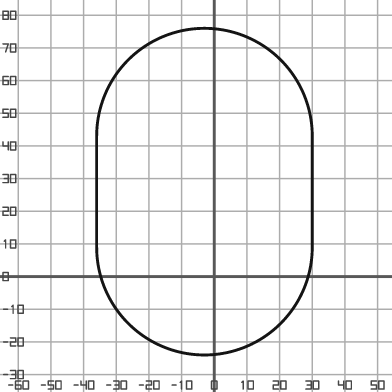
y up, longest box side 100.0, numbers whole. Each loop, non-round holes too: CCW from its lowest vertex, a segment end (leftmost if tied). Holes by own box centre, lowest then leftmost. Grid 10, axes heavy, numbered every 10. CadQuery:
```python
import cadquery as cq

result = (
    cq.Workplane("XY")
    .moveTo(-36.0, 9.0)
    .threePointArc((-3.0, -24.0), (30.0, 9.0))
    .lineTo(30.0, 43.0)
    .threePointArc((-3.0, 76.0), (-36.0, 43.0))
    .close()
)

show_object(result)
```